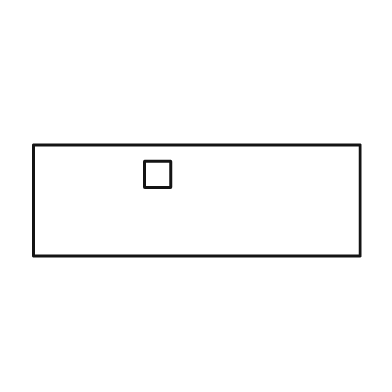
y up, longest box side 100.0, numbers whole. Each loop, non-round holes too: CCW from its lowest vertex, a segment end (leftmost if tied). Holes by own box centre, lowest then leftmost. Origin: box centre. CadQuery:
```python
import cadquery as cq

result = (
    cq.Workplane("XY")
    .moveTo(-50.0, -17.0)
    .lineTo(50.0, -17.0)
    .lineTo(50.0, 17.0)
    .lineTo(-50.0, 17.0)
    .close()
    .moveTo(-16.0, 4.0)
    .lineTo(-8.0, 4.0)
    .lineTo(-8.0, 12.0)
    .lineTo(-16.0, 12.0)
    .close()
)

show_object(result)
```